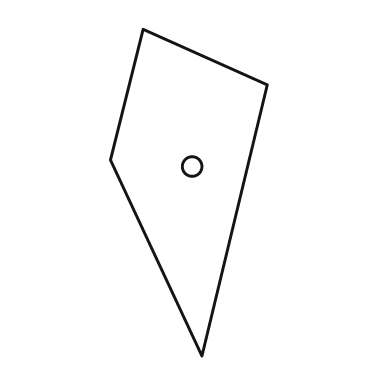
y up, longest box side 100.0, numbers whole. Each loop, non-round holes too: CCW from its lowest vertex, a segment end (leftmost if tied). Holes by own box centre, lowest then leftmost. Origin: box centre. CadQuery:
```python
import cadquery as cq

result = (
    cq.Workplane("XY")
    .moveTo(4.0, -50.0)
    .lineTo(24.0, 33.0)
    .lineTo(-14.0, 50.0)
    .lineTo(-24.0, 10.0)
    .close()
    .moveTo(1.0, 8.0)
    .circle(3.0)
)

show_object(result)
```